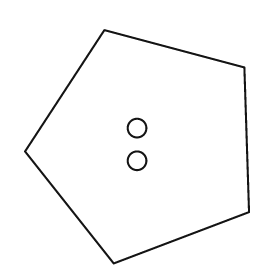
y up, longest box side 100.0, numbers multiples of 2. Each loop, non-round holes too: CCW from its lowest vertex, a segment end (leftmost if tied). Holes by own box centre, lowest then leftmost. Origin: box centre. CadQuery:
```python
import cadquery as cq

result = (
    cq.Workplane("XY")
    .moveTo(-10.0, -50.0)
    .lineTo(48.0, -28.0)
    .lineTo(46.0, 34.0)
    .lineTo(-14.0, 50.0)
    .lineTo(-48.0, -2.0)
    .close()
    .moveTo(0.0, -6.0)
    .circle(4.0)
    .moveTo(0.0, 8.0)
    .circle(4.0)
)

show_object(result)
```